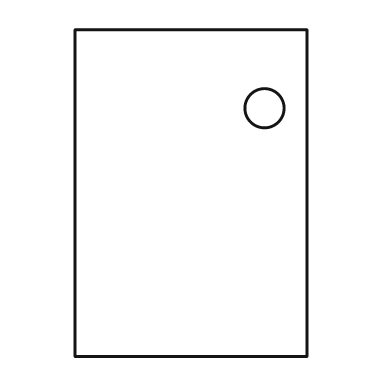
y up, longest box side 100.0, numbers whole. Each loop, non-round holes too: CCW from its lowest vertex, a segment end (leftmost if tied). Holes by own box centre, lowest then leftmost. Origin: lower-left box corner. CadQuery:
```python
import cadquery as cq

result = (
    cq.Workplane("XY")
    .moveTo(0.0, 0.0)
    .lineTo(71.0, 0.0)
    .lineTo(71.0, 100.0)
    .lineTo(0.0, 100.0)
    .close()
    .moveTo(58.0, 76.0)
    .circle(6.0)
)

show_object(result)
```